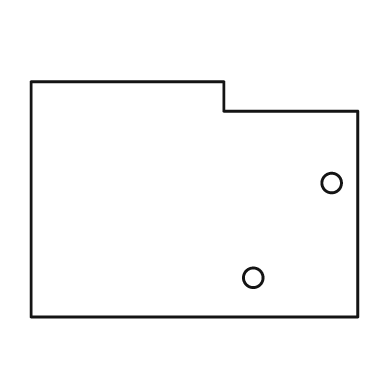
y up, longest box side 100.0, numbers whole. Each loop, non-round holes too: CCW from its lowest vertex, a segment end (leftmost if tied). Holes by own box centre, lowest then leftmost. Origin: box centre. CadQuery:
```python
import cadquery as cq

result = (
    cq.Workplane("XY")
    .moveTo(-50.0, -36.0)
    .lineTo(50.0, -36.0)
    .lineTo(50.0, 27.0)
    .lineTo(9.0, 27.0)
    .lineTo(9.0, 36.0)
    .lineTo(-50.0, 36.0)
    .close()
    .moveTo(18.0, -24.0)
    .circle(3.0)
    .moveTo(42.0, 5.0)
    .circle(3.0)
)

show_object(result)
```